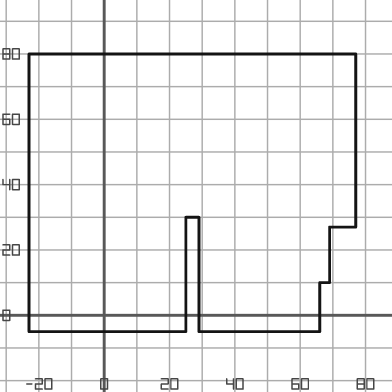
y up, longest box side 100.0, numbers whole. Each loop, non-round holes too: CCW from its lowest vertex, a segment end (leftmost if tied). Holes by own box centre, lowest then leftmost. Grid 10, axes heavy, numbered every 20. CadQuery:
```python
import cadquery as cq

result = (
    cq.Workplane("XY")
    .moveTo(-23.0, -5.0)
    .lineTo(25.0, -5.0)
    .lineTo(25.0, 30.0)
    .lineTo(29.0, 30.0)
    .lineTo(29.0, -5.0)
    .lineTo(66.0, -5.0)
    .lineTo(66.0, 10.0)
    .lineTo(69.0, 10.0)
    .lineTo(69.0, 27.0)
    .lineTo(77.0, 27.0)
    .lineTo(77.0, 80.0)
    .lineTo(-23.0, 80.0)
    .close()
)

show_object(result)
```